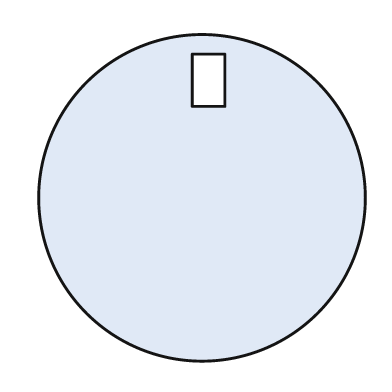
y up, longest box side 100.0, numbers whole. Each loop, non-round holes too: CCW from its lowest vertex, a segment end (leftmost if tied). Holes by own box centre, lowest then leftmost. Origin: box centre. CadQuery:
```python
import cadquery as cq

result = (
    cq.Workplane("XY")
    .moveTo(0.0, 0.0)
    .circle(50.0)
    .moveTo(-3.0, 28.0)
    .lineTo(7.0, 28.0)
    .lineTo(7.0, 44.0)
    .lineTo(-3.0, 44.0)
    .close()
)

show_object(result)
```